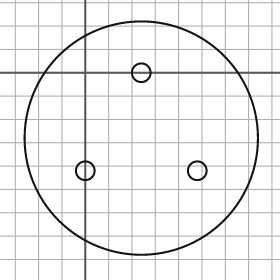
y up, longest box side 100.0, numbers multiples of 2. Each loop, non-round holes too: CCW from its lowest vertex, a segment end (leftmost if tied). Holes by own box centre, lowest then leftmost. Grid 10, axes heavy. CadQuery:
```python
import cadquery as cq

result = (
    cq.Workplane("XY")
    .moveTo(24.0, -28.0)
    .circle(50.0)
    .moveTo(0.0, -42.0)
    .circle(4.0)
    .moveTo(48.0, -42.0)
    .circle(4.0)
    .moveTo(24.0, 0.0)
    .circle(4.0)
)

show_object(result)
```